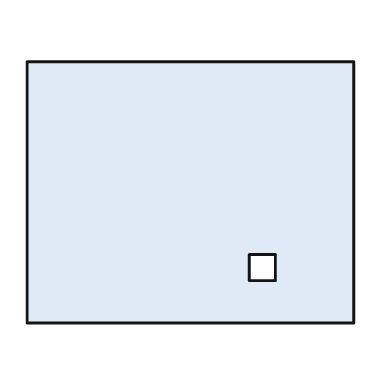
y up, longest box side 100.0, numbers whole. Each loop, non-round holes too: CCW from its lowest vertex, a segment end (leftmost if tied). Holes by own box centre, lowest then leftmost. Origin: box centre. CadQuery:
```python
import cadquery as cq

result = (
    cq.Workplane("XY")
    .moveTo(-50.0, -40.0)
    .lineTo(50.0, -40.0)
    .lineTo(50.0, 40.0)
    .lineTo(-50.0, 40.0)
    .close()
    .moveTo(18.0, -27.0)
    .lineTo(26.0, -27.0)
    .lineTo(26.0, -19.0)
    .lineTo(18.0, -19.0)
    .close()
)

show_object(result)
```